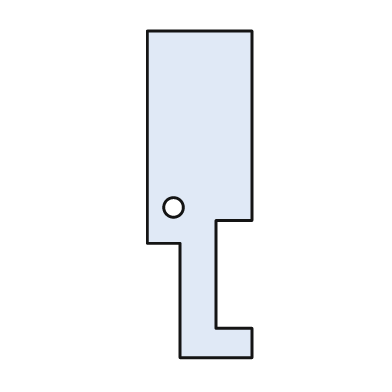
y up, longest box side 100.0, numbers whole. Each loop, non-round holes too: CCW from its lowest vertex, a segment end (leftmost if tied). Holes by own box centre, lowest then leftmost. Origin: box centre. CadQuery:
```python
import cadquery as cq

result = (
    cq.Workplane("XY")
    .moveTo(-6.0, -50.0)
    .lineTo(16.0, -50.0)
    .lineTo(16.0, -41.0)
    .lineTo(5.0, -41.0)
    .lineTo(5.0, -8.0)
    .lineTo(16.0, -8.0)
    .lineTo(16.0, 50.0)
    .lineTo(-16.0, 50.0)
    .lineTo(-16.0, -15.0)
    .lineTo(-6.0, -15.0)
    .close()
    .moveTo(-8.0, -4.0)
    .circle(3.0)
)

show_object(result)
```